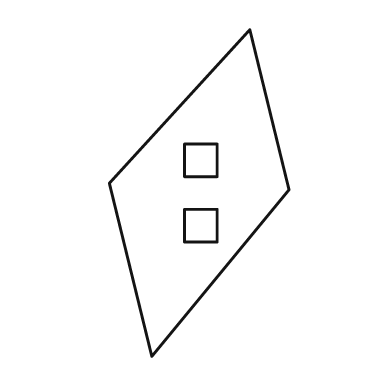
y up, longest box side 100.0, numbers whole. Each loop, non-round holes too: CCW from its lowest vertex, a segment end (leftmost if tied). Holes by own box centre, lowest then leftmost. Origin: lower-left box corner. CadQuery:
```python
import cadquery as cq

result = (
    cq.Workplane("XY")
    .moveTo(13.0, 0.0)
    .lineTo(55.0, 51.0)
    .lineTo(43.0, 100.0)
    .lineTo(0.0, 53.0)
    .close()
    .moveTo(23.0, 35.0)
    .lineTo(33.0, 35.0)
    .lineTo(33.0, 45.0)
    .lineTo(23.0, 45.0)
    .close()
    .moveTo(23.0, 55.0)
    .lineTo(33.0, 55.0)
    .lineTo(33.0, 65.0)
    .lineTo(23.0, 65.0)
    .close()
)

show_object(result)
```